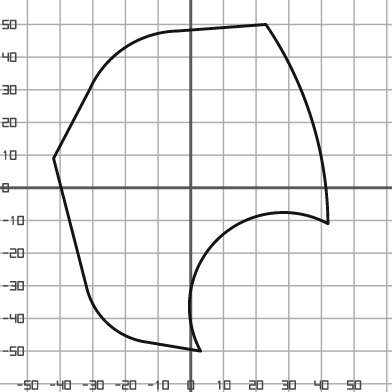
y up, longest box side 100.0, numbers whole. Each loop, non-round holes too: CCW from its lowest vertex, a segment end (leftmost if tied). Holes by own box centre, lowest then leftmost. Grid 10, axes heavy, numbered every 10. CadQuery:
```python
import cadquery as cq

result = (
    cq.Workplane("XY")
    .moveTo(3.0, -50.0)
    .threePointArc((8.0, -16.0), (42.0, -11.0))
    .threePointArc((37.0, 21.0), (23.0, 50.0))
    .lineTo(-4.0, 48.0)
    .threePointArc((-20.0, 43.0), (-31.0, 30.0))
    .lineTo(-42.0, 9.0)
    .lineTo(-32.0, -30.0)
    .threePointArc((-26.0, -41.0), (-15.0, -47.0))
    .close()
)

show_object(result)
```